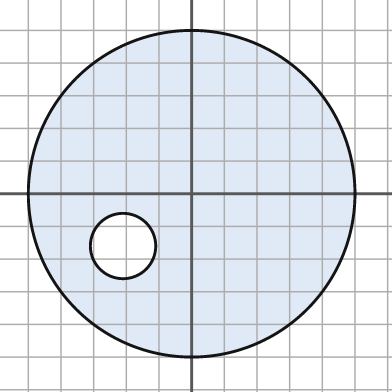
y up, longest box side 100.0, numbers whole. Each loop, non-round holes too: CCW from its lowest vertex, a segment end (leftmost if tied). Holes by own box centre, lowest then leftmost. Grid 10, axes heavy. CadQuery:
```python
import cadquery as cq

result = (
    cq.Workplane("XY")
    .moveTo(0.0, 0.0)
    .circle(50.0)
    .moveTo(-21.0, -16.0)
    .circle(10.0)
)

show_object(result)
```